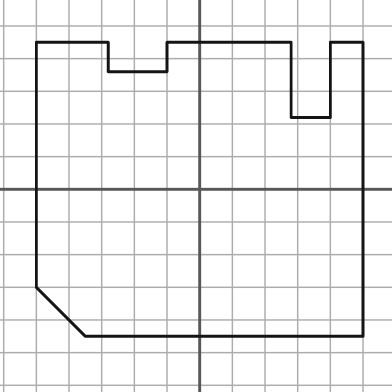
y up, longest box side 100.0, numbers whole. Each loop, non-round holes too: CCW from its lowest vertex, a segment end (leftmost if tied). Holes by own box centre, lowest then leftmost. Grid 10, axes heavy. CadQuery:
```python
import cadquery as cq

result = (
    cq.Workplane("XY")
    .moveTo(-35.0, -45.0)
    .lineTo(50.0, -45.0)
    .lineTo(50.0, 45.0)
    .lineTo(40.0, 45.0)
    .lineTo(40.0, 22.0)
    .lineTo(28.0, 22.0)
    .lineTo(28.0, 45.0)
    .lineTo(-10.0, 45.0)
    .lineTo(-10.0, 36.0)
    .lineTo(-28.0, 36.0)
    .lineTo(-28.0, 45.0)
    .lineTo(-50.0, 45.0)
    .lineTo(-50.0, -30.0)
    .close()
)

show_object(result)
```